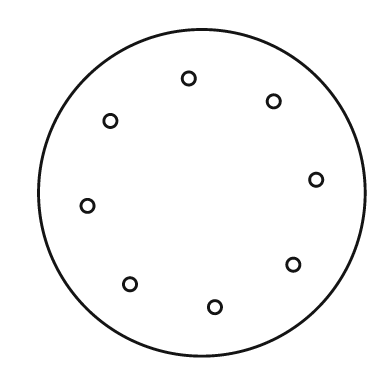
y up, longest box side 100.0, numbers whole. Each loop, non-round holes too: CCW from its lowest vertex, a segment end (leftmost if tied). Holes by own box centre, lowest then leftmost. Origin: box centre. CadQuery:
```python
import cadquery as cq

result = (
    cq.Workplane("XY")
    .moveTo(0.0, 0.0)
    .circle(50.0)
    .moveTo(4.0, -35.0)
    .circle(2.0)
    .moveTo(-22.0, -28.0)
    .circle(2.0)
    .moveTo(28.0, -22.0)
    .circle(2.0)
    .moveTo(-35.0, -4.0)
    .circle(2.0)
    .moveTo(35.0, 4.0)
    .circle(2.0)
    .moveTo(-28.0, 22.0)
    .circle(2.0)
    .moveTo(22.0, 28.0)
    .circle(2.0)
    .moveTo(-4.0, 35.0)
    .circle(2.0)
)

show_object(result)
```